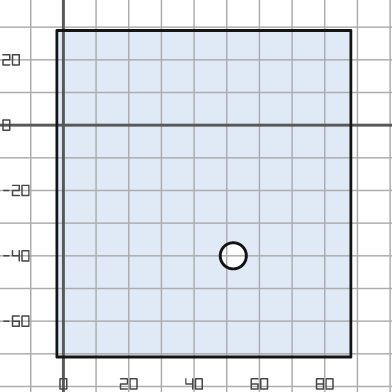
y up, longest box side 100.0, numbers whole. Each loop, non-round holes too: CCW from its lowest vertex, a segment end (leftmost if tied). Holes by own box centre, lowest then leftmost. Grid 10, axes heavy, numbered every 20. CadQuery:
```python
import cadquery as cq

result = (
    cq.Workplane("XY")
    .moveTo(-2.0, -71.0)
    .lineTo(88.0, -71.0)
    .lineTo(88.0, 29.0)
    .lineTo(-2.0, 29.0)
    .close()
    .moveTo(52.0, -40.0)
    .circle(4.0)
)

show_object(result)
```